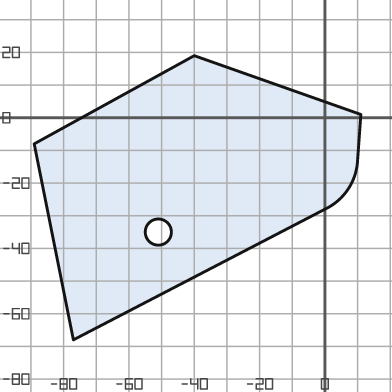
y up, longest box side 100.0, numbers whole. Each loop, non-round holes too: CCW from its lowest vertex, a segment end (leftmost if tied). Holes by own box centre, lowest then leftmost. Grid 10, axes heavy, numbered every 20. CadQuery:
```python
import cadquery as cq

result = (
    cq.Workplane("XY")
    .moveTo(-77.0, -68.0)
    .lineTo(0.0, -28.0)
    .threePointArc((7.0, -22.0), (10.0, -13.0))
    .lineTo(11.0, 1.0)
    .lineTo(-40.0, 19.0)
    .lineTo(-89.0, -8.0)
    .close()
    .moveTo(-51.0, -35.0)
    .circle(4.0)
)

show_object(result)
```